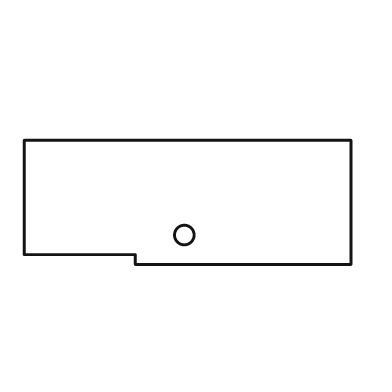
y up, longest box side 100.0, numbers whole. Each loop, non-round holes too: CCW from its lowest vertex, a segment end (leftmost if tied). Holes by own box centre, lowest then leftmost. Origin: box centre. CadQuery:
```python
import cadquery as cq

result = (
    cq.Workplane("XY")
    .moveTo(-16.0, -19.0)
    .lineTo(50.0, -19.0)
    .lineTo(50.0, 19.0)
    .lineTo(-50.0, 19.0)
    .lineTo(-50.0, -16.0)
    .lineTo(-16.0, -16.0)
    .close()
    .moveTo(-1.0, -10.0)
    .circle(3.0)
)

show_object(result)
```